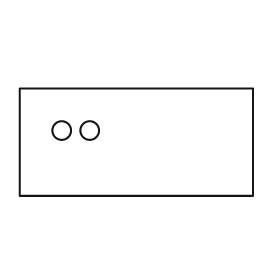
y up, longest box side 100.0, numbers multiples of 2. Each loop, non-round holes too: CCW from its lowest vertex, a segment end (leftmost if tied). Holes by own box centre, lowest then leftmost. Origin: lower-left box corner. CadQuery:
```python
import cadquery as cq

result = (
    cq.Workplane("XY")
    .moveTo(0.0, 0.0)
    .lineTo(100.0, 0.0)
    .lineTo(100.0, 46.0)
    .lineTo(0.0, 46.0)
    .close()
    .moveTo(18.0, 28.0)
    .circle(4.0)
    .moveTo(30.0, 28.0)
    .circle(4.0)
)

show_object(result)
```